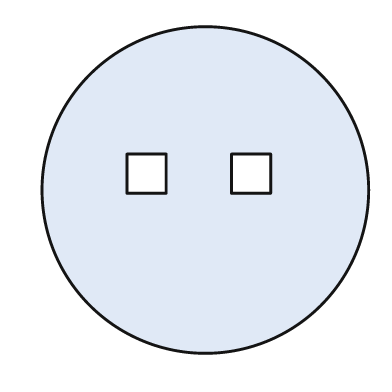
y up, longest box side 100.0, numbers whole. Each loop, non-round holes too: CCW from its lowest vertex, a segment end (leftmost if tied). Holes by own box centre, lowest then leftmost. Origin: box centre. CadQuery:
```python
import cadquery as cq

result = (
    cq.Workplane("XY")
    .moveTo(0.0, 0.0)
    .circle(50.0)
    .moveTo(-24.0, -1.0)
    .lineTo(-12.0, -1.0)
    .lineTo(-12.0, 11.0)
    .lineTo(-24.0, 11.0)
    .close()
    .moveTo(8.0, -1.0)
    .lineTo(20.0, -1.0)
    .lineTo(20.0, 11.0)
    .lineTo(8.0, 11.0)
    .close()
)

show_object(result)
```